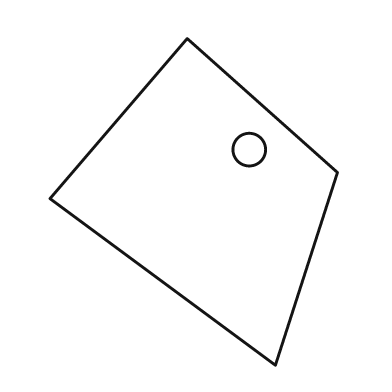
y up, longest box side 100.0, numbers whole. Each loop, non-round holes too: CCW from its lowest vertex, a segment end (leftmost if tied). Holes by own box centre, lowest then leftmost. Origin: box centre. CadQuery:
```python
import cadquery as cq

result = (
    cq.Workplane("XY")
    .moveTo(25.0, -50.0)
    .lineTo(44.0, 9.0)
    .lineTo(-2.0, 50.0)
    .lineTo(-44.0, 1.0)
    .close()
    .moveTo(17.0, 16.0)
    .circle(5.0)
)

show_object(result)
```